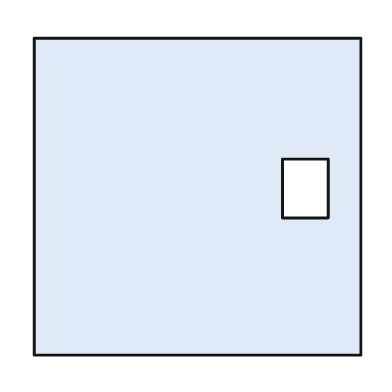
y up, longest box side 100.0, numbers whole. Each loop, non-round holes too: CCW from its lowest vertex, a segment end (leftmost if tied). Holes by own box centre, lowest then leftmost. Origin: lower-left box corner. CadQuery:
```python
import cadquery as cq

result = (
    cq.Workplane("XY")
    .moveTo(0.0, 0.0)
    .lineTo(100.0, 0.0)
    .lineTo(100.0, 97.0)
    .lineTo(0.0, 97.0)
    .close()
    .moveTo(76.0, 42.0)
    .lineTo(90.0, 42.0)
    .lineTo(90.0, 60.0)
    .lineTo(76.0, 60.0)
    .close()
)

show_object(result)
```